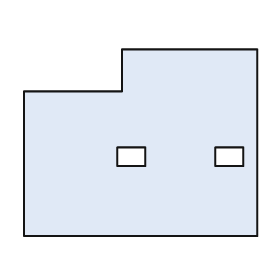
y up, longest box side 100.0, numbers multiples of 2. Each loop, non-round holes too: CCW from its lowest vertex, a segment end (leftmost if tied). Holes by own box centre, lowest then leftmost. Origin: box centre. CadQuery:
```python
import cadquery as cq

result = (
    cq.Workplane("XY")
    .moveTo(-50.0, -40.0)
    .lineTo(50.0, -40.0)
    .lineTo(50.0, 40.0)
    .lineTo(-8.0, 40.0)
    .lineTo(-8.0, 22.0)
    .lineTo(-50.0, 22.0)
    .close()
    .moveTo(-10.0, -10.0)
    .lineTo(2.0, -10.0)
    .lineTo(2.0, -2.0)
    .lineTo(-10.0, -2.0)
    .close()
    .moveTo(32.0, -10.0)
    .lineTo(44.0, -10.0)
    .lineTo(44.0, -2.0)
    .lineTo(32.0, -2.0)
    .close()
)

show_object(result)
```